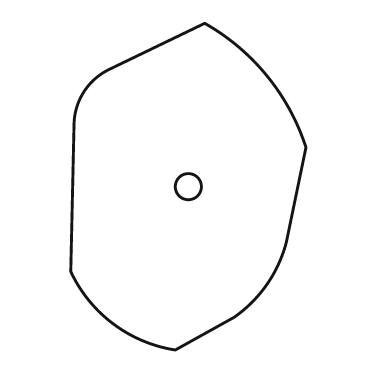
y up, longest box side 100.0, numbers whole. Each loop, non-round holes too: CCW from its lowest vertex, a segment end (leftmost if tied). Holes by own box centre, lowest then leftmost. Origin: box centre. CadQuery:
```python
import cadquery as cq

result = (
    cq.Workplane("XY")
    .moveTo(-4.0, -50.0)
    .lineTo(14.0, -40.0)
    .threePointArc((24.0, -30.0), (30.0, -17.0))
    .lineTo(36.0, 12.0)
    .threePointArc((24.0, 34.0), (5.0, 50.0))
    .lineTo(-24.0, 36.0)
    .threePointArc((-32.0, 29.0), (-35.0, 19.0))
    .lineTo(-36.0, -26.0)
    .threePointArc((-23.0, -42.0), (-4.0, -50.0))
    .close()
    .moveTo(0.0, 0.0)
    .circle(4.0)
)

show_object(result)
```